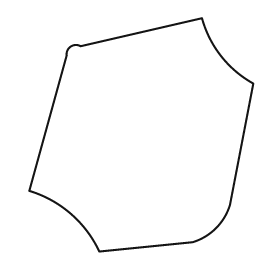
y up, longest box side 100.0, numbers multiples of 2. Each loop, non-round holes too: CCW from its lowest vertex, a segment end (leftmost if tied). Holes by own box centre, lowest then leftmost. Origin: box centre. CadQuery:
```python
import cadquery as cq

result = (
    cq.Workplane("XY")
    .moveTo(-18.0, -50.0)
    .lineTo(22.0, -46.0)
    .threePointArc((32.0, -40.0), (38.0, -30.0))
    .lineTo(48.0, 22.0)
    .threePointArc((34.0, 34.0), (26.0, 50.0))
    .lineTo(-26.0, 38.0)
    .threePointArc((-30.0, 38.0), (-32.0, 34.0))
    .lineTo(-48.0, -24.0)
    .threePointArc((-30.0, -34.0), (-18.0, -50.0))
    .close()
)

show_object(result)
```